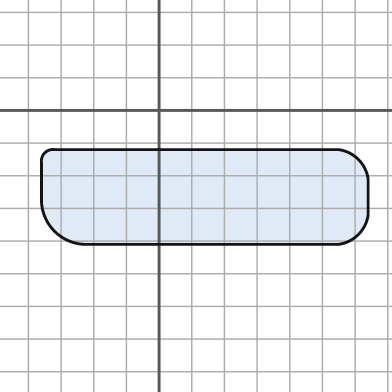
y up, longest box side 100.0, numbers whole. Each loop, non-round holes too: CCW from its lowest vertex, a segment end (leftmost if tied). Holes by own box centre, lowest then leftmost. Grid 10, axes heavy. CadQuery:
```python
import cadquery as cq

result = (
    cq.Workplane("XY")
    .moveTo(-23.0, -41.0)
    .lineTo(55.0, -41.0)
    .threePointArc((61.0, -38.0), (64.0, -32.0))
    .lineTo(64.0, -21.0)
    .threePointArc((61.0, -15.0), (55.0, -12.0))
    .lineTo(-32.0, -12.0)
    .threePointArc((-35.0, -13.0), (-36.0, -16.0))
    .lineTo(-36.0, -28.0)
    .threePointArc((-32.0, -37.0), (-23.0, -41.0))
    .close()
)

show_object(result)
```